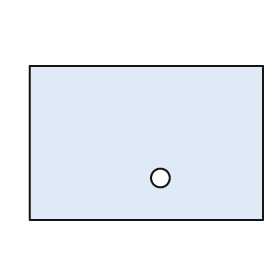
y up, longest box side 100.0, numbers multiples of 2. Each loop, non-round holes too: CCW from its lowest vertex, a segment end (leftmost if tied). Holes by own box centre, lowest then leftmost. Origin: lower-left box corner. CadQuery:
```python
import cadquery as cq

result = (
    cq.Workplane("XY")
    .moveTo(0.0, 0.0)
    .lineTo(100.0, 0.0)
    .lineTo(100.0, 66.0)
    .lineTo(0.0, 66.0)
    .close()
    .moveTo(56.0, 18.0)
    .circle(4.0)
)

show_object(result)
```